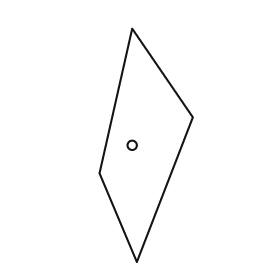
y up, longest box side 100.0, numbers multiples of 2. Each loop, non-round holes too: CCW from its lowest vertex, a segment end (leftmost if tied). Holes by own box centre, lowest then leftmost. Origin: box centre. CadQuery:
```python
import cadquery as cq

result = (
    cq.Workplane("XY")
    .moveTo(-4.0, -50.0)
    .lineTo(20.0, 12.0)
    .lineTo(-6.0, 50.0)
    .lineTo(-20.0, -12.0)
    .close()
    .moveTo(-6.0, 0.0)
    .circle(2.0)
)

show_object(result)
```